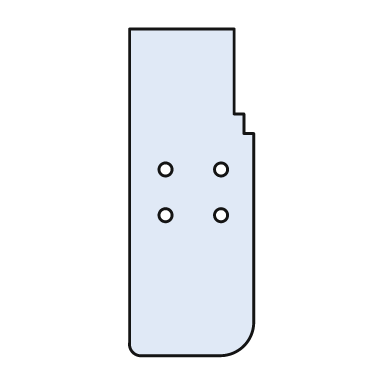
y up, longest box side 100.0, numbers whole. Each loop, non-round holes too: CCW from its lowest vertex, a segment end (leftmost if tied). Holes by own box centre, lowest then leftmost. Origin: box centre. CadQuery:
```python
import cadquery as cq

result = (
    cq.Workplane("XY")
    .moveTo(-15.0, -50.0)
    .lineTo(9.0, -50.0)
    .threePointArc((16.0, -47.0), (19.0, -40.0))
    .lineTo(19.0, 18.0)
    .lineTo(16.0, 18.0)
    .lineTo(16.0, 24.0)
    .lineTo(13.0, 24.0)
    .lineTo(13.0, 50.0)
    .lineTo(-19.0, 50.0)
    .lineTo(-19.0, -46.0)
    .threePointArc((-18.0, -49.0), (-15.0, -50.0))
    .close()
    .moveTo(-8.0, -7.0)
    .circle(2.0)
    .moveTo(9.0, -7.0)
    .circle(2.0)
    .moveTo(-8.0, 7.0)
    .circle(2.0)
    .moveTo(9.0, 7.0)
    .circle(2.0)
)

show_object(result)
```